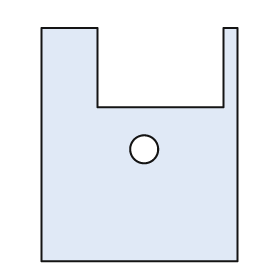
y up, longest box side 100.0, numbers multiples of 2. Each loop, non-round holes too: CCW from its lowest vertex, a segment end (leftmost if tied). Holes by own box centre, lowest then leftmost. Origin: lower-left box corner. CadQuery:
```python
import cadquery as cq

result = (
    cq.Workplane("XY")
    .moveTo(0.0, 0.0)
    .lineTo(84.0, 0.0)
    .lineTo(84.0, 100.0)
    .lineTo(78.0, 100.0)
    .lineTo(78.0, 66.0)
    .lineTo(24.0, 66.0)
    .lineTo(24.0, 100.0)
    .lineTo(0.0, 100.0)
    .close()
    .moveTo(44.0, 48.0)
    .circle(6.0)
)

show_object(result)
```